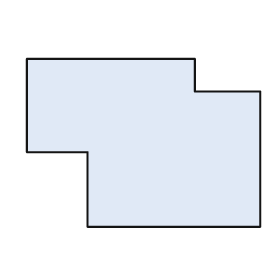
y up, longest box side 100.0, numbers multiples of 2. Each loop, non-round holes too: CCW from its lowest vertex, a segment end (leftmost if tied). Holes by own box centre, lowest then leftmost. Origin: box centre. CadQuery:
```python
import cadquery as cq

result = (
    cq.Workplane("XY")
    .moveTo(-24.0, -36.0)
    .lineTo(50.0, -36.0)
    .lineTo(50.0, 22.0)
    .lineTo(22.0, 22.0)
    .lineTo(22.0, 36.0)
    .lineTo(-50.0, 36.0)
    .lineTo(-50.0, -4.0)
    .lineTo(-24.0, -4.0)
    .close()
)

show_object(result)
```